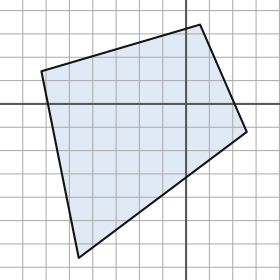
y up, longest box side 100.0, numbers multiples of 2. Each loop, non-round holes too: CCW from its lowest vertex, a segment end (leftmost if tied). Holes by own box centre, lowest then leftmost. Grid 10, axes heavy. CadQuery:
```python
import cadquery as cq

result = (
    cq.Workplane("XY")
    .moveTo(-46.0, -66.0)
    .lineTo(26.0, -12.0)
    .lineTo(6.0, 34.0)
    .lineTo(-62.0, 14.0)
    .close()
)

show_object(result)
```